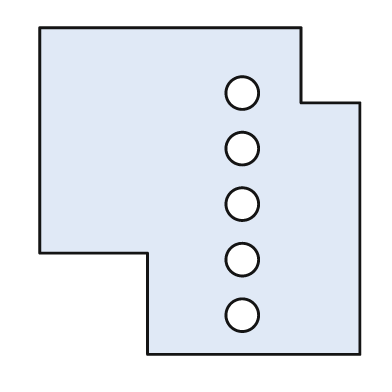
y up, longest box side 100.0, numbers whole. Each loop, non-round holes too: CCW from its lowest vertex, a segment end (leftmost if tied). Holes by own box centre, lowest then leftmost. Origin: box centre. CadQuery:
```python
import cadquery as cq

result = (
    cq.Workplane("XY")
    .moveTo(-16.0, -50.0)
    .lineTo(49.0, -50.0)
    .lineTo(49.0, 27.0)
    .lineTo(31.0, 27.0)
    .lineTo(31.0, 50.0)
    .lineTo(-49.0, 50.0)
    .lineTo(-49.0, -19.0)
    .lineTo(-16.0, -19.0)
    .close()
    .moveTo(13.0, -38.0)
    .circle(5.0)
    .moveTo(13.0, -21.0)
    .circle(5.0)
    .moveTo(13.0, -4.0)
    .circle(5.0)
    .moveTo(13.0, 13.0)
    .circle(5.0)
    .moveTo(13.0, 30.0)
    .circle(5.0)
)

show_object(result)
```